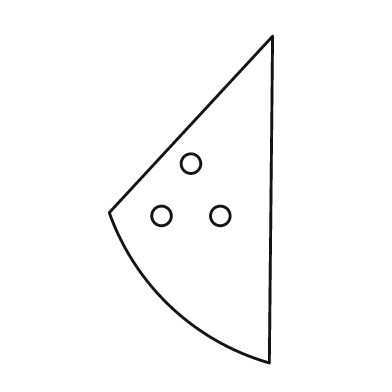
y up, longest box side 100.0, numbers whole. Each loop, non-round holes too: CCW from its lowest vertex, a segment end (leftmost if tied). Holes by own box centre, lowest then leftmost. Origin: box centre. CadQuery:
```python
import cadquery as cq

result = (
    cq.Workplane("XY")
    .moveTo(24.0, -50.0)
    .lineTo(25.0, 50.0)
    .lineTo(-25.0, -4.0)
    .threePointArc((-6.0, -33.0), (24.0, -50.0))
    .close()
    .moveTo(-9.0, -5.0)
    .circle(3.0)
    .moveTo(9.0, -5.0)
    .circle(3.0)
    .moveTo(0.0, 11.0)
    .circle(3.0)
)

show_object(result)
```